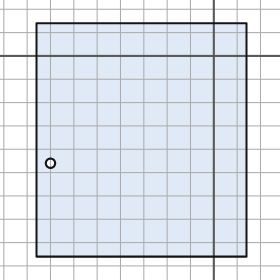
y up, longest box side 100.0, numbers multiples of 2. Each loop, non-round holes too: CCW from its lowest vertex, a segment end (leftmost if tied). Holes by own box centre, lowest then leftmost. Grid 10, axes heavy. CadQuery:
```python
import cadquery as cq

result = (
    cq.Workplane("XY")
    .moveTo(-76.0, -86.0)
    .lineTo(14.0, -86.0)
    .lineTo(14.0, 14.0)
    .lineTo(-76.0, 14.0)
    .close()
    .moveTo(-70.0, -46.0)
    .circle(2.0)
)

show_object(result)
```